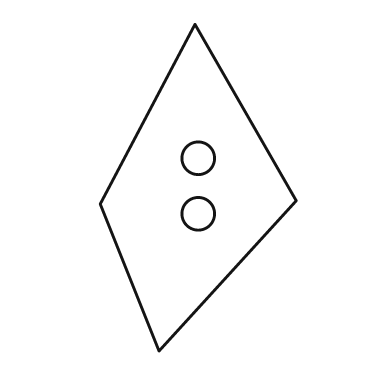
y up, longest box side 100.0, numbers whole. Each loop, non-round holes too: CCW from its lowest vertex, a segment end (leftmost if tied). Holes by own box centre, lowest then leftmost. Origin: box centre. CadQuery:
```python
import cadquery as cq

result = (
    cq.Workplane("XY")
    .moveTo(-12.0, -50.0)
    .lineTo(30.0, -4.0)
    .lineTo(-1.0, 50.0)
    .lineTo(-30.0, -5.0)
    .close()
    .moveTo(0.0, -8.0)
    .circle(5.0)
    .moveTo(0.0, 9.0)
    .circle(5.0)
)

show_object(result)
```